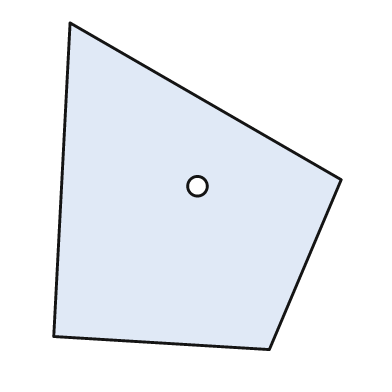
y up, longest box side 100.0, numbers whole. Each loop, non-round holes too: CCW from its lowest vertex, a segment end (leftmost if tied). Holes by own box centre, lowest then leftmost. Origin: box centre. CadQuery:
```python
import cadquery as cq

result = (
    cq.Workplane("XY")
    .moveTo(22.0, -50.0)
    .lineTo(44.0, 2.0)
    .lineTo(-39.0, 50.0)
    .lineTo(-44.0, -46.0)
    .close()
    .moveTo(0.0, 0.0)
    .circle(3.0)
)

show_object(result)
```